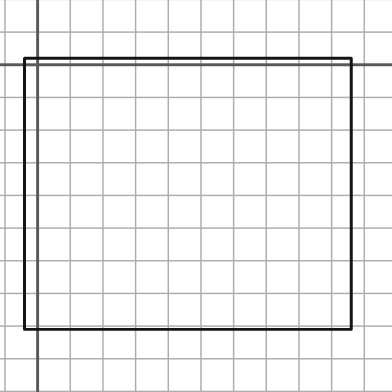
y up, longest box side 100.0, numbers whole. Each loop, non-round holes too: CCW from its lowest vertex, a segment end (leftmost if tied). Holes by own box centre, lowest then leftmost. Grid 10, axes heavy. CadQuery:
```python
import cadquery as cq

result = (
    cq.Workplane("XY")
    .moveTo(-4.0, -81.0)
    .lineTo(96.0, -81.0)
    .lineTo(96.0, 2.0)
    .lineTo(-4.0, 2.0)
    .close()
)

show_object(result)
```